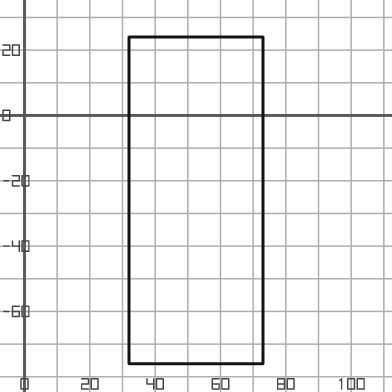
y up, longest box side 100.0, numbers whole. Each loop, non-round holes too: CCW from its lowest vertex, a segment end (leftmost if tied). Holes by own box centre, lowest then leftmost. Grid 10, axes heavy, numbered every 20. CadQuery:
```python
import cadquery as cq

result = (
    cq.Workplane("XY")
    .moveTo(32.0, -76.0)
    .lineTo(73.0, -76.0)
    .lineTo(73.0, 24.0)
    .lineTo(32.0, 24.0)
    .close()
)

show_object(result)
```